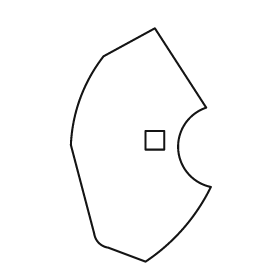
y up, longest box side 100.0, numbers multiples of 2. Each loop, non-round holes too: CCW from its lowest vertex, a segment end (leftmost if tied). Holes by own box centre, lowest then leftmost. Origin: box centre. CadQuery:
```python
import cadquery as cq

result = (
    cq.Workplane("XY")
    .moveTo(2.0, -50.0)
    .threePointArc((18.0, -36.0), (30.0, -18.0))
    .threePointArc((16.0, -2.0), (28.0, 16.0))
    .lineTo(6.0, 50.0)
    .lineTo(-16.0, 38.0)
    .threePointArc((-26.0, 20.0), (-30.0, 0.0))
    .lineTo(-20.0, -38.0)
    .threePointArc((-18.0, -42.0), (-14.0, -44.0))
    .close()
    .moveTo(2.0, -2.0)
    .lineTo(10.0, -2.0)
    .lineTo(10.0, 6.0)
    .lineTo(2.0, 6.0)
    .close()
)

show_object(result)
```